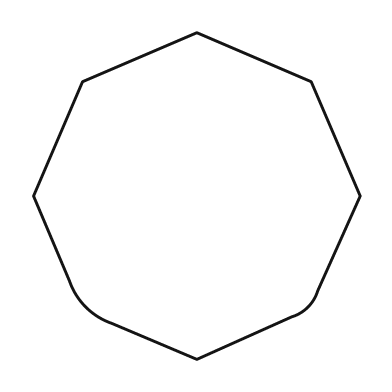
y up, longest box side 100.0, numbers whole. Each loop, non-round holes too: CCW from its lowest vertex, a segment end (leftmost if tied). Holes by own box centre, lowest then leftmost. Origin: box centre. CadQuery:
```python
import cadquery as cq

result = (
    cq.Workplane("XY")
    .moveTo(0.0, -50.0)
    .lineTo(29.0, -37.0)
    .threePointArc((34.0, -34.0), (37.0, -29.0))
    .lineTo(50.0, 0.0)
    .lineTo(35.0, 35.0)
    .lineTo(0.0, 50.0)
    .lineTo(-35.0, 35.0)
    .lineTo(-50.0, 0.0)
    .lineTo(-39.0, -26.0)
    .threePointArc((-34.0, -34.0), (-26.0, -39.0))
    .close()
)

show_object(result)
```